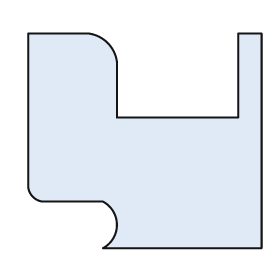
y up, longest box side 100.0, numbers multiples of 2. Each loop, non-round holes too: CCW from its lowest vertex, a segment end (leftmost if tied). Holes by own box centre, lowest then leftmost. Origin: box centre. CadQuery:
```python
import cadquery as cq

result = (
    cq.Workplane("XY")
    .moveTo(-18.0, -46.0)
    .lineTo(50.0, -46.0)
    .lineTo(50.0, 46.0)
    .lineTo(40.0, 46.0)
    .lineTo(40.0, 10.0)
    .lineTo(-12.0, 10.0)
    .lineTo(-12.0, 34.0)
    .threePointArc((-16.0, 42.0), (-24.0, 46.0))
    .lineTo(-50.0, 46.0)
    .lineTo(-50.0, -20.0)
    .threePointArc((-48.0, -24.0), (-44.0, -26.0))
    .lineTo(-18.0, -26.0)
    .threePointArc((-12.0, -36.0), (-18.0, -46.0))
    .close()
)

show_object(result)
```